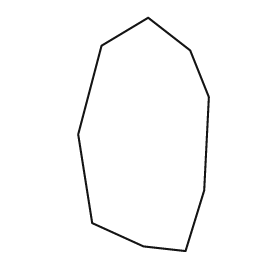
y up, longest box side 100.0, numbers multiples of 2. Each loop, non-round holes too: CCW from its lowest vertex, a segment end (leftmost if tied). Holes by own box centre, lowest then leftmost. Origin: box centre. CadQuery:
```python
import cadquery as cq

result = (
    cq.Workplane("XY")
    .moveTo(18.0, -50.0)
    .lineTo(26.0, -24.0)
    .lineTo(28.0, 16.0)
    .lineTo(20.0, 36.0)
    .lineTo(2.0, 50.0)
    .lineTo(-18.0, 38.0)
    .lineTo(-28.0, 0.0)
    .lineTo(-22.0, -38.0)
    .lineTo(0.0, -48.0)
    .close()
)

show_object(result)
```